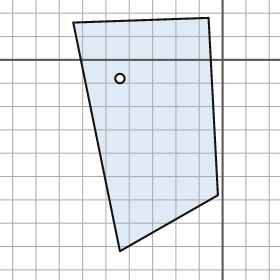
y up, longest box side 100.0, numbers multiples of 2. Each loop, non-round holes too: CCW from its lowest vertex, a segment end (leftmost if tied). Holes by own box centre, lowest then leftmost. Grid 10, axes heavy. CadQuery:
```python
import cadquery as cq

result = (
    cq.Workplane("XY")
    .moveTo(-44.0, -82.0)
    .lineTo(-2.0, -58.0)
    .lineTo(-6.0, 18.0)
    .lineTo(-64.0, 16.0)
    .close()
    .moveTo(-44.0, -8.0)
    .circle(2.0)
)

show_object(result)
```